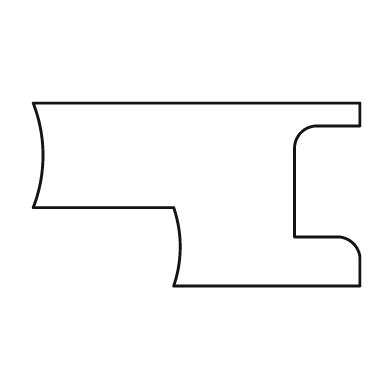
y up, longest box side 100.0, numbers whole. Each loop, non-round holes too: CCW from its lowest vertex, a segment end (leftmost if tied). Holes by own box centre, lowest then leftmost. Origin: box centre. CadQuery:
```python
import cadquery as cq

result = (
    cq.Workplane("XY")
    .moveTo(-7.0, -28.0)
    .lineTo(50.0, -28.0)
    .lineTo(50.0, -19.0)
    .threePointArc((48.0, -15.0), (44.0, -13.0))
    .lineTo(30.0, -13.0)
    .lineTo(30.0, 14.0)
    .threePointArc((32.0, 19.0), (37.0, 21.0))
    .lineTo(50.0, 21.0)
    .lineTo(50.0, 28.0)
    .lineTo(-50.0, 28.0)
    .threePointArc((-47.0, 12.0), (-50.0, -4.0))
    .lineTo(-7.0, -4.0)
    .threePointArc((-5.0, -16.0), (-7.0, -28.0))
    .close()
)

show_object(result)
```